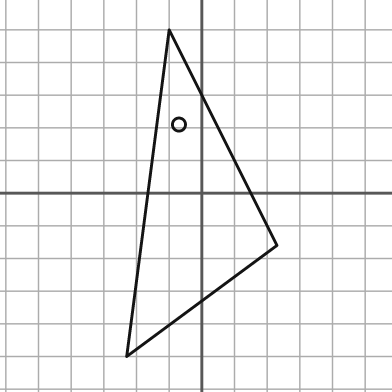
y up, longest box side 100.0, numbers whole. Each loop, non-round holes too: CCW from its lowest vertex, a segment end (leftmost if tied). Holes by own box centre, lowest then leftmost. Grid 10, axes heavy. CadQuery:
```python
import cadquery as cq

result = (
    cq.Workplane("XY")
    .moveTo(-23.0, -50.0)
    .lineTo(23.0, -16.0)
    .lineTo(-10.0, 50.0)
    .close()
    .moveTo(-7.0, 21.0)
    .circle(2.0)
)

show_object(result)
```